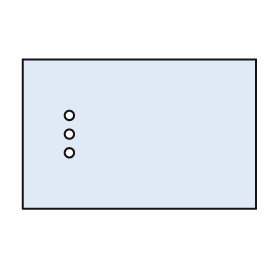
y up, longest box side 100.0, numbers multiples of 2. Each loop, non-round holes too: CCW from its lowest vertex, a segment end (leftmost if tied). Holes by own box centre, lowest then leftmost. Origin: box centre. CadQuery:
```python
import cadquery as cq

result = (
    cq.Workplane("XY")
    .moveTo(-50.0, -32.0)
    .lineTo(50.0, -32.0)
    .lineTo(50.0, 32.0)
    .lineTo(-50.0, 32.0)
    .close()
    .moveTo(-30.0, -8.0)
    .circle(2.0)
    .moveTo(-30.0, 0.0)
    .circle(2.0)
    .moveTo(-30.0, 8.0)
    .circle(2.0)
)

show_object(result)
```